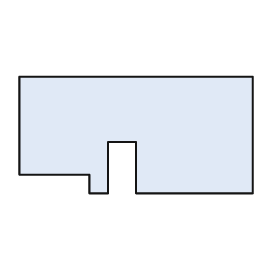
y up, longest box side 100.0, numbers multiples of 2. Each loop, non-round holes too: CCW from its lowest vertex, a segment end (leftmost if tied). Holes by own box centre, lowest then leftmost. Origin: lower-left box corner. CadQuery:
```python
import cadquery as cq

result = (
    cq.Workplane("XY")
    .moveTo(30.0, 0.0)
    .lineTo(38.0, 0.0)
    .lineTo(38.0, 22.0)
    .lineTo(50.0, 22.0)
    .lineTo(50.0, 0.0)
    .lineTo(100.0, 0.0)
    .lineTo(100.0, 50.0)
    .lineTo(0.0, 50.0)
    .lineTo(0.0, 8.0)
    .lineTo(30.0, 8.0)
    .close()
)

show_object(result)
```